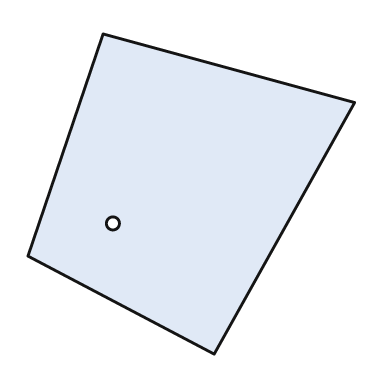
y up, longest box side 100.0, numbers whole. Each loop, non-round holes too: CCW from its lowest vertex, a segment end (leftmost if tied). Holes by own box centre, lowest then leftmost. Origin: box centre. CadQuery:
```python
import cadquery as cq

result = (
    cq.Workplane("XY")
    .moveTo(7.0, -49.0)
    .lineTo(50.0, 28.0)
    .lineTo(-27.0, 49.0)
    .lineTo(-50.0, -19.0)
    .close()
    .moveTo(-24.0, -9.0)
    .circle(2.0)
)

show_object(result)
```